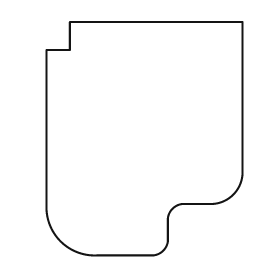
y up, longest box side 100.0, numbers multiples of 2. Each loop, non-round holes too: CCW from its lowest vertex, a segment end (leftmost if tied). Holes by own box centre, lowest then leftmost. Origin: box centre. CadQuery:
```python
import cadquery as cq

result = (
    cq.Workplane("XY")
    .moveTo(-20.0, -50.0)
    .lineTo(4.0, -50.0)
    .threePointArc((8.0, -48.0), (10.0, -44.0))
    .lineTo(10.0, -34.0)
    .threePointArc((12.0, -30.0), (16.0, -28.0))
    .lineTo(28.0, -28.0)
    .threePointArc((38.0, -24.0), (42.0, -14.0))
    .lineTo(42.0, 50.0)
    .lineTo(-32.0, 50.0)
    .lineTo(-32.0, 38.0)
    .lineTo(-42.0, 38.0)
    .lineTo(-42.0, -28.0)
    .threePointArc((-36.0, -44.0), (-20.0, -50.0))
    .close()
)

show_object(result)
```